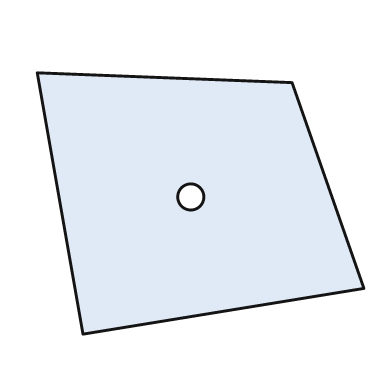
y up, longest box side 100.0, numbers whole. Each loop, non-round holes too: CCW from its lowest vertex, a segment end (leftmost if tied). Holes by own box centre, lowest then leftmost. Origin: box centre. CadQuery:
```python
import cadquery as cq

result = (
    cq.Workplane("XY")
    .moveTo(-36.0, -40.0)
    .lineTo(50.0, -26.0)
    .lineTo(28.0, 37.0)
    .lineTo(-50.0, 40.0)
    .close()
    .moveTo(-3.0, 2.0)
    .circle(4.0)
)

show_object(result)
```